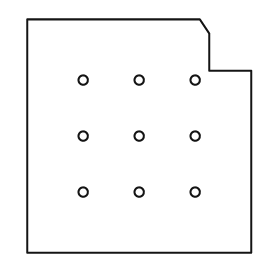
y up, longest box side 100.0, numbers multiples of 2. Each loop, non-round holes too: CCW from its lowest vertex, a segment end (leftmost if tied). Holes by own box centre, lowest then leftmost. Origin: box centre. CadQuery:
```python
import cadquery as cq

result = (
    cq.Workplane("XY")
    .moveTo(-48.0, -50.0)
    .lineTo(48.0, -50.0)
    .lineTo(48.0, 28.0)
    .lineTo(30.0, 28.0)
    .lineTo(30.0, 44.0)
    .lineTo(26.0, 50.0)
    .lineTo(-48.0, 50.0)
    .close()
    .moveTo(-24.0, -24.0)
    .circle(2.0)
    .moveTo(0.0, -24.0)
    .circle(2.0)
    .moveTo(24.0, -24.0)
    .circle(2.0)
    .moveTo(-24.0, 0.0)
    .circle(2.0)
    .moveTo(0.0, 0.0)
    .circle(2.0)
    .moveTo(24.0, 0.0)
    .circle(2.0)
    .moveTo(-24.0, 24.0)
    .circle(2.0)
    .moveTo(0.0, 24.0)
    .circle(2.0)
    .moveTo(24.0, 24.0)
    .circle(2.0)
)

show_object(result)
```